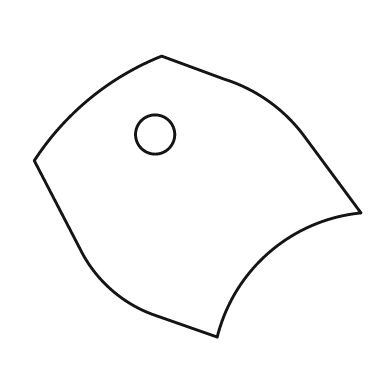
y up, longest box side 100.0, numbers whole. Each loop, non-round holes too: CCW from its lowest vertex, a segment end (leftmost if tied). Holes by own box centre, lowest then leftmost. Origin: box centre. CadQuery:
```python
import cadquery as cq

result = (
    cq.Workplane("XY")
    .moveTo(6.0, -43.0)
    .threePointArc((22.0, -17.0), (50.0, -5.0))
    .lineTo(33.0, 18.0)
    .threePointArc((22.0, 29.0), (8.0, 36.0))
    .lineTo(-11.0, 43.0)
    .threePointArc((-33.0, 30.0), (-50.0, 11.0))
    .lineTo(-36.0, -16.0)
    .threePointArc((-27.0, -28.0), (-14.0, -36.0))
    .close()
    .moveTo(-13.0, 19.0)
    .circle(6.0)
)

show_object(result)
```